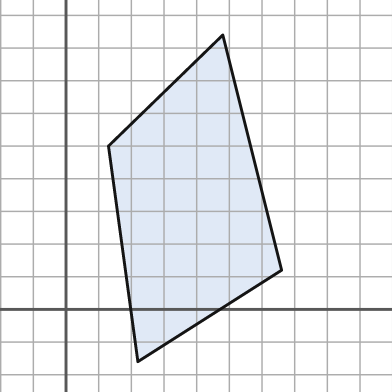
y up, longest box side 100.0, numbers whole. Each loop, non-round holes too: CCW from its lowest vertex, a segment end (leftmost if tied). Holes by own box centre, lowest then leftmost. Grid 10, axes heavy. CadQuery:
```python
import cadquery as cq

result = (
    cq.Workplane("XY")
    .moveTo(22.0, -16.0)
    .lineTo(66.0, 12.0)
    .lineTo(48.0, 84.0)
    .lineTo(13.0, 50.0)
    .close()
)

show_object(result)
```